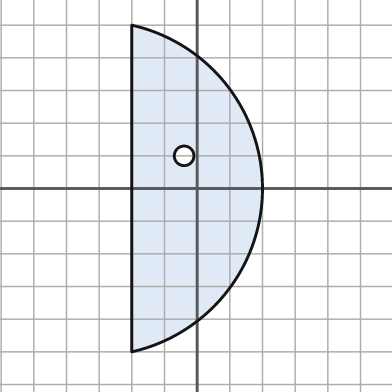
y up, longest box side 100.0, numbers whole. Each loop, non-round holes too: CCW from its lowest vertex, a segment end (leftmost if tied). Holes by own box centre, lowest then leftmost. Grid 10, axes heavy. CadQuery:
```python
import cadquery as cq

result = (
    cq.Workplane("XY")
    .moveTo(-20.0, -50.0)
    .threePointArc((20.0, 0.0), (-20.0, 50.0))
    .close()
    .moveTo(-4.0, 10.0)
    .circle(3.0)
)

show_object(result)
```